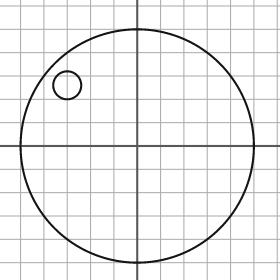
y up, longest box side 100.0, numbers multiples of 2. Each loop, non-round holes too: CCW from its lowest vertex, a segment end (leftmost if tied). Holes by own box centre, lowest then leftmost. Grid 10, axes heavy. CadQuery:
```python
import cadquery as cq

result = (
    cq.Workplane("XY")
    .moveTo(0.0, 0.0)
    .circle(50.0)
    .moveTo(-30.0, 26.0)
    .circle(6.0)
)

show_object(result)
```